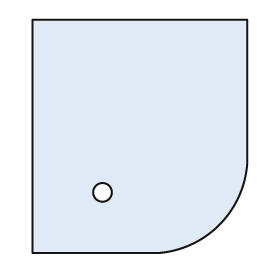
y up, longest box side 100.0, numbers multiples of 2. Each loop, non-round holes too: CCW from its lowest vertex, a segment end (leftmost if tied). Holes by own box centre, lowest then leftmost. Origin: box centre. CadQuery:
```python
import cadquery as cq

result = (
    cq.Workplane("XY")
    .moveTo(-46.0, -50.0)
    .lineTo(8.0, -50.0)
    .threePointArc((34.0, -38.0), (46.0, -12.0))
    .lineTo(46.0, 50.0)
    .lineTo(-46.0, 50.0)
    .close()
    .moveTo(-16.0, -24.0)
    .circle(4.0)
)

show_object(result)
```